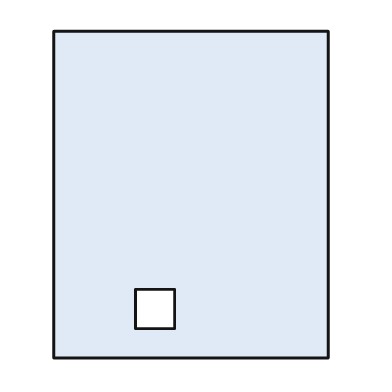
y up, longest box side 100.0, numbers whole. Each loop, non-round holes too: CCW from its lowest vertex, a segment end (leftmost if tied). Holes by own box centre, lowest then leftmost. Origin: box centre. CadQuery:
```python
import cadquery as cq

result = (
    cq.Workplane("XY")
    .moveTo(-42.0, -50.0)
    .lineTo(42.0, -50.0)
    .lineTo(42.0, 50.0)
    .lineTo(-42.0, 50.0)
    .close()
    .moveTo(-17.0, -41.0)
    .lineTo(-5.0, -41.0)
    .lineTo(-5.0, -29.0)
    .lineTo(-17.0, -29.0)
    .close()
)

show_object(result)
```